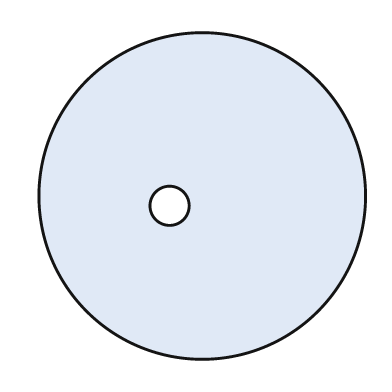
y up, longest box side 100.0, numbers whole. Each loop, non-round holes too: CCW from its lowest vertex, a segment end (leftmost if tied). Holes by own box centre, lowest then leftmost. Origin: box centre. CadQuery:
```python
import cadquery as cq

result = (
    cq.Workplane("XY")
    .moveTo(0.0, 0.0)
    .circle(50.0)
    .moveTo(-10.0, -3.0)
    .circle(6.0)
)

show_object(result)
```